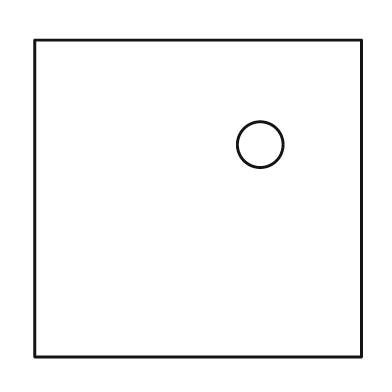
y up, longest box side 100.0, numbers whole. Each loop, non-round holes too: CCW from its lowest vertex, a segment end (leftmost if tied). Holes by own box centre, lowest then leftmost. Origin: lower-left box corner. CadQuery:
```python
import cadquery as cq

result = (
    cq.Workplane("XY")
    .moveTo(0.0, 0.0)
    .lineTo(100.0, 0.0)
    .lineTo(100.0, 97.0)
    .lineTo(0.0, 97.0)
    .close()
    .moveTo(69.0, 65.0)
    .circle(7.0)
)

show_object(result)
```